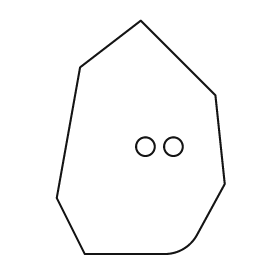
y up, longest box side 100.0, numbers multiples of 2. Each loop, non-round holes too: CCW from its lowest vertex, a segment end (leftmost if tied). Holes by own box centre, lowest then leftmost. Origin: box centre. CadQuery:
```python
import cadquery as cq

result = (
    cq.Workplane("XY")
    .moveTo(-24.0, -50.0)
    .lineTo(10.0, -50.0)
    .threePointArc((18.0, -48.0), (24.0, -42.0))
    .lineTo(36.0, -20.0)
    .lineTo(32.0, 18.0)
    .lineTo(0.0, 50.0)
    .lineTo(-26.0, 30.0)
    .lineTo(-36.0, -26.0)
    .close()
    .moveTo(2.0, -4.0)
    .circle(4.0)
    .moveTo(14.0, -4.0)
    .circle(4.0)
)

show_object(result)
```